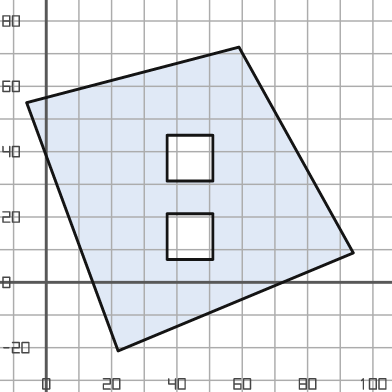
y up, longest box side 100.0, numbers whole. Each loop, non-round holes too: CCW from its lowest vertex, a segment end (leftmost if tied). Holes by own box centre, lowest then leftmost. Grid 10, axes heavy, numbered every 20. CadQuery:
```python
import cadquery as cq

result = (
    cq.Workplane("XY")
    .moveTo(22.0, -21.0)
    .lineTo(94.0, 9.0)
    .lineTo(59.0, 72.0)
    .lineTo(-6.0, 55.0)
    .close()
    .moveTo(37.0, 7.0)
    .lineTo(51.0, 7.0)
    .lineTo(51.0, 21.0)
    .lineTo(37.0, 21.0)
    .close()
    .moveTo(37.0, 31.0)
    .lineTo(51.0, 31.0)
    .lineTo(51.0, 45.0)
    .lineTo(37.0, 45.0)
    .close()
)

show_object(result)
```